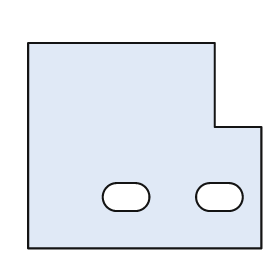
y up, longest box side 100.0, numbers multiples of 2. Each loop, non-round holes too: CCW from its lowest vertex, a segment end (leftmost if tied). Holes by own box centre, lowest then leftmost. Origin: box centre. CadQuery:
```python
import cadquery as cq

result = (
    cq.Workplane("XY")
    .moveTo(-50.0, -44.0)
    .lineTo(50.0, -44.0)
    .lineTo(50.0, 8.0)
    .lineTo(30.0, 8.0)
    .lineTo(30.0, 44.0)
    .lineTo(-50.0, 44.0)
    .close()
    .moveTo(-12.0, -28.0)
    .lineTo(-4.0, -28.0)
    .threePointArc((2.0, -22.0), (-4.0, -16.0))
    .lineTo(-12.0, -16.0)
    .threePointArc((-18.0, -22.0), (-12.0, -28.0))
    .close()
    .moveTo(28.0, -28.0)
    .lineTo(36.0, -28.0)
    .threePointArc((42.0, -22.0), (36.0, -16.0))
    .lineTo(28.0, -16.0)
    .threePointArc((22.0, -22.0), (28.0, -28.0))
    .close()
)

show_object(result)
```